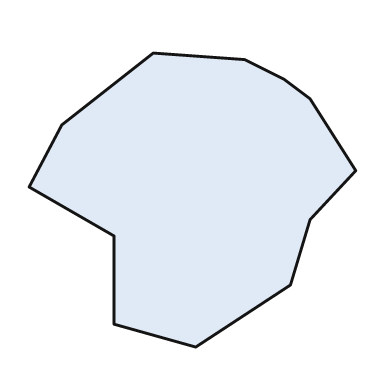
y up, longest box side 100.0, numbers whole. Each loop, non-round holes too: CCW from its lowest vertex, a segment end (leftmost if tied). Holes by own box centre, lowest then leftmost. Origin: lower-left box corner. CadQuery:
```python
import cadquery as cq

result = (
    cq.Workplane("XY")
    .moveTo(51.0, 0.0)
    .lineTo(80.0, 19.0)
    .lineTo(86.0, 39.0)
    .lineTo(100.0, 54.0)
    .lineTo(86.0, 76.0)
    .lineTo(78.0, 82.0)
    .lineTo(66.0, 88.0)
    .lineTo(38.0, 90.0)
    .lineTo(10.0, 68.0)
    .lineTo(0.0, 49.0)
    .lineTo(26.0, 34.0)
    .lineTo(26.0, 7.0)
    .close()
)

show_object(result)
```